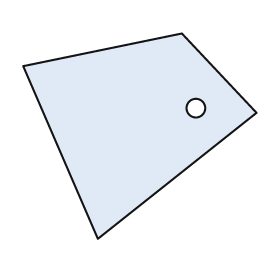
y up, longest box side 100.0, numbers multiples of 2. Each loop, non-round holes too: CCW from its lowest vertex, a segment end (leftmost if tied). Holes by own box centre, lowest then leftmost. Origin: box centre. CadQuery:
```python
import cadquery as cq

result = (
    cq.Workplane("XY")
    .moveTo(-18.0, -44.0)
    .lineTo(50.0, 10.0)
    .lineTo(18.0, 44.0)
    .lineTo(-50.0, 30.0)
    .close()
    .moveTo(24.0, 12.0)
    .circle(4.0)
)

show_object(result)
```